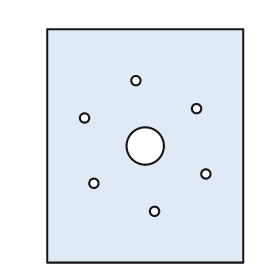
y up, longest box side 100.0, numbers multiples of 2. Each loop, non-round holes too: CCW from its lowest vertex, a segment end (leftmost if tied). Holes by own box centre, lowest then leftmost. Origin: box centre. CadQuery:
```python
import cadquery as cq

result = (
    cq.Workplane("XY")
    .moveTo(-42.0, -50.0)
    .lineTo(42.0, -50.0)
    .lineTo(42.0, 50.0)
    .lineTo(-42.0, 50.0)
    .close()
    .moveTo(4.0, -28.0)
    .circle(2.0)
    .moveTo(-22.0, -16.0)
    .circle(2.0)
    .moveTo(26.0, -12.0)
    .circle(2.0)
    .moveTo(0.0, 0.0)
    .circle(8.0)
    .moveTo(-26.0, 12.0)
    .circle(2.0)
    .moveTo(22.0, 16.0)
    .circle(2.0)
    .moveTo(-4.0, 28.0)
    .circle(2.0)
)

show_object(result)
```